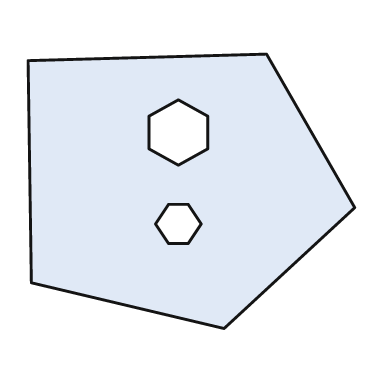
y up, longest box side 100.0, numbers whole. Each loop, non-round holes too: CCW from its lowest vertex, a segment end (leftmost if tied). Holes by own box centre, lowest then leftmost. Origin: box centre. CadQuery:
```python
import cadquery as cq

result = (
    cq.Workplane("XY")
    .moveTo(10.0, -42.0)
    .lineTo(50.0, -5.0)
    .lineTo(23.0, 42.0)
    .lineTo(-50.0, 40.0)
    .lineTo(-49.0, -28.0)
    .close()
    .moveTo(-7.0, -16.0)
    .lineTo(-1.0, -16.0)
    .lineTo(3.0, -10.0)
    .lineTo(-1.0, -4.0)
    .lineTo(-7.0, -4.0)
    .lineTo(-11.0, -10.0)
    .close()
    .moveTo(-4.0, 8.0)
    .lineTo(5.0, 13.0)
    .lineTo(5.0, 23.0)
    .lineTo(-4.0, 28.0)
    .lineTo(-13.0, 23.0)
    .lineTo(-13.0, 13.0)
    .close()
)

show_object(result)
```